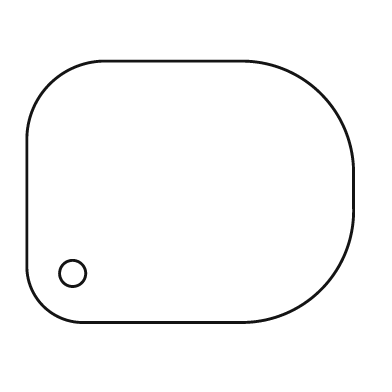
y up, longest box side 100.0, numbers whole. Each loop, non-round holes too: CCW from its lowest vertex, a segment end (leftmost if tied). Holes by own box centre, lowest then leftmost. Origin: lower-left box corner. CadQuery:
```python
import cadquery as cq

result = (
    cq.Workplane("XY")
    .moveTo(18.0, 0.0)
    .lineTo(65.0, 0.0)
    .threePointArc((90.0, 10.0), (100.0, 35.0))
    .lineTo(100.0, 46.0)
    .threePointArc((90.0, 70.0), (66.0, 80.0))
    .lineTo(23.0, 80.0)
    .threePointArc((7.0, 73.0), (0.0, 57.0))
    .lineTo(0.0, 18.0)
    .threePointArc((5.0, 5.0), (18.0, 0.0))
    .close()
    .moveTo(14.0, 15.0)
    .circle(4.0)
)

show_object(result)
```